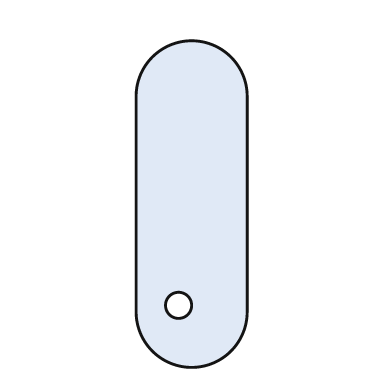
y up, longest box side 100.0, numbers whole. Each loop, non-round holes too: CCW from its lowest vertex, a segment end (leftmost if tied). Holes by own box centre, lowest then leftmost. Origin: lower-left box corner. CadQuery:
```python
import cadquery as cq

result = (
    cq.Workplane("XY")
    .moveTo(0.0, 17.0)
    .threePointArc((17.0, 0.0), (34.0, 17.0))
    .lineTo(34.0, 83.0)
    .threePointArc((17.0, 100.0), (0.0, 83.0))
    .close()
    .moveTo(13.0, 19.0)
    .circle(4.0)
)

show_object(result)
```